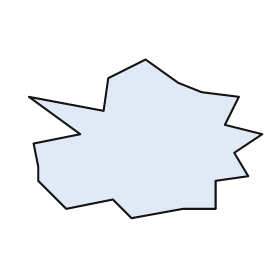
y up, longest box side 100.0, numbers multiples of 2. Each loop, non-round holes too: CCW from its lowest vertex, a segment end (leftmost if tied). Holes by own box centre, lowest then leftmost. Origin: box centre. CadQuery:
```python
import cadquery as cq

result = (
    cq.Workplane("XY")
    .moveTo(-6.0, -34.0)
    .lineTo(16.0, -30.0)
    .lineTo(30.0, -30.0)
    .lineTo(30.0, -18.0)
    .lineTo(44.0, -16.0)
    .lineTo(38.0, -6.0)
    .lineTo(50.0, 2.0)
    .lineTo(34.0, 6.0)
    .lineTo(40.0, 18.0)
    .lineTo(24.0, 20.0)
    .lineTo(14.0, 24.0)
    .lineTo(0.0, 34.0)
    .lineTo(-16.0, 26.0)
    .lineTo(-18.0, 12.0)
    .lineTo(-50.0, 18.0)
    .lineTo(-28.0, 2.0)
    .lineTo(-48.0, -2.0)
    .lineTo(-46.0, -12.0)
    .lineTo(-46.0, -18.0)
    .lineTo(-34.0, -30.0)
    .lineTo(-14.0, -26.0)
    .close()
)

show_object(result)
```